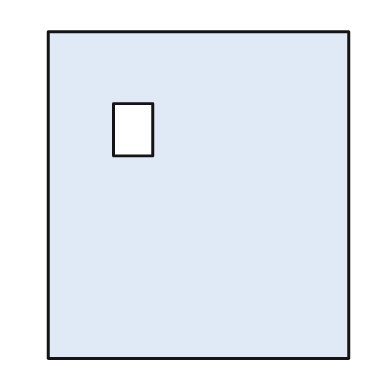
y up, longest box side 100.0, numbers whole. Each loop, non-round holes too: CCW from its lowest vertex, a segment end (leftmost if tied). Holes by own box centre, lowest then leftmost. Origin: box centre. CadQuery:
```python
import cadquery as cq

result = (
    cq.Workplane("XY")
    .moveTo(-46.0, -50.0)
    .lineTo(46.0, -50.0)
    .lineTo(46.0, 50.0)
    .lineTo(-46.0, 50.0)
    .close()
    .moveTo(-26.0, 12.0)
    .lineTo(-14.0, 12.0)
    .lineTo(-14.0, 28.0)
    .lineTo(-26.0, 28.0)
    .close()
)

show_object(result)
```